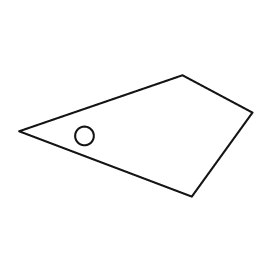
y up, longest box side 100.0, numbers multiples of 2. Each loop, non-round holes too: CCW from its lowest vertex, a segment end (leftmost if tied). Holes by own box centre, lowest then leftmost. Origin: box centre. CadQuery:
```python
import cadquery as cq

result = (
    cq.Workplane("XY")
    .moveTo(24.0, -26.0)
    .lineTo(50.0, 10.0)
    .lineTo(20.0, 26.0)
    .lineTo(-50.0, 2.0)
    .close()
    .moveTo(-22.0, 0.0)
    .circle(4.0)
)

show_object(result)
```